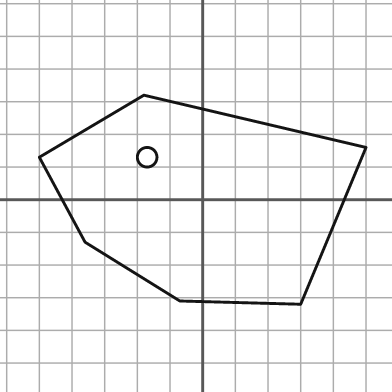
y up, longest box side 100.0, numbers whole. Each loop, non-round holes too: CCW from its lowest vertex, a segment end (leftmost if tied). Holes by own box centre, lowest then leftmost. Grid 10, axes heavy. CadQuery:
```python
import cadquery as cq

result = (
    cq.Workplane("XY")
    .moveTo(30.0, -32.0)
    .lineTo(50.0, 16.0)
    .lineTo(-18.0, 32.0)
    .lineTo(-50.0, 13.0)
    .lineTo(-36.0, -13.0)
    .lineTo(-7.0, -31.0)
    .close()
    .moveTo(-17.0, 13.0)
    .circle(3.0)
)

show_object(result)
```